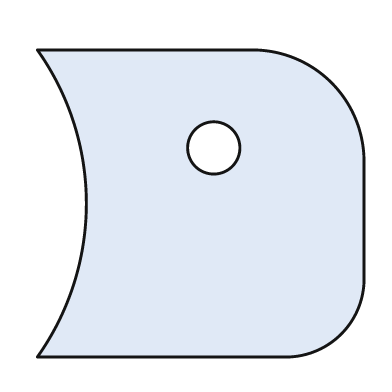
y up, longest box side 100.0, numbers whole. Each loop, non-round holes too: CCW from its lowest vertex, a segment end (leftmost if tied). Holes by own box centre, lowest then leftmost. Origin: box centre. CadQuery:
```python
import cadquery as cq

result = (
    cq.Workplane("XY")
    .moveTo(-50.0, -47.0)
    .lineTo(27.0, -47.0)
    .threePointArc((43.0, -40.0), (50.0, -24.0))
    .lineTo(50.0, 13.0)
    .threePointArc((40.0, 37.0), (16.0, 47.0))
    .lineTo(-50.0, 47.0)
    .threePointArc((-35.0, 0.0), (-50.0, -47.0))
    .close()
    .moveTo(4.0, 17.0)
    .circle(8.0)
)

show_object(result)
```